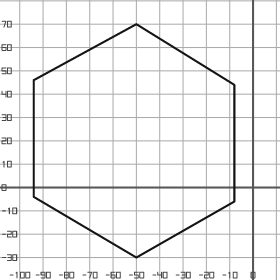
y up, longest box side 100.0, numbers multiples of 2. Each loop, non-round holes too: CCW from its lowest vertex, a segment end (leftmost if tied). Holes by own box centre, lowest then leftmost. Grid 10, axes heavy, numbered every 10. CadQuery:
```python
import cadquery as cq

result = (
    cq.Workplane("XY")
    .moveTo(-50.0, -30.0)
    .lineTo(-8.0, -6.0)
    .lineTo(-8.0, 44.0)
    .lineTo(-50.0, 70.0)
    .lineTo(-94.0, 46.0)
    .lineTo(-94.0, -4.0)
    .close()
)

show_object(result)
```